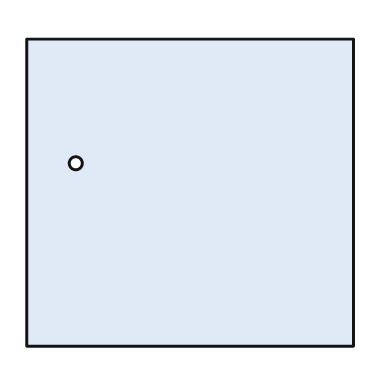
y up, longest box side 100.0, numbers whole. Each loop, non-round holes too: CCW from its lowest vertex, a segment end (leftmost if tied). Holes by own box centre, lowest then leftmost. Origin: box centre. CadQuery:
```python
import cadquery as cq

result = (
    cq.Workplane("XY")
    .moveTo(-50.0, -47.0)
    .lineTo(50.0, -47.0)
    .lineTo(50.0, 47.0)
    .lineTo(-50.0, 47.0)
    .close()
    .moveTo(-35.0, 9.0)
    .circle(2.0)
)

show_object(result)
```